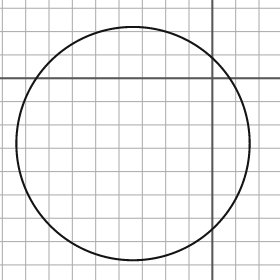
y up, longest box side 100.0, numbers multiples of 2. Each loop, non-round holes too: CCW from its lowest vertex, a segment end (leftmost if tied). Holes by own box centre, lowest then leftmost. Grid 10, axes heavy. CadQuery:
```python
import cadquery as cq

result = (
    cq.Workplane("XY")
    .moveTo(-34.0, -28.0)
    .circle(50.0)
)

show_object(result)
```